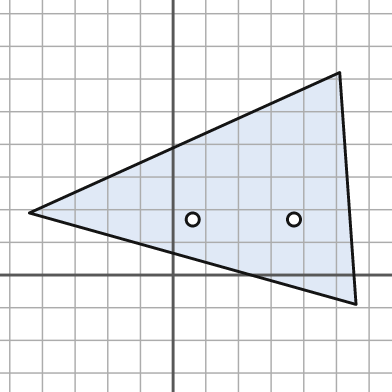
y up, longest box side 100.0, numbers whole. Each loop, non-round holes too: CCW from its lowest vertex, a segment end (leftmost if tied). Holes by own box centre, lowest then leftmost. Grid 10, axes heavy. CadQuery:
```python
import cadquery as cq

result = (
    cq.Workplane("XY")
    .moveTo(56.0, -9.0)
    .lineTo(51.0, 62.0)
    .lineTo(-44.0, 19.0)
    .close()
    .moveTo(6.0, 17.0)
    .circle(2.0)
    .moveTo(37.0, 17.0)
    .circle(2.0)
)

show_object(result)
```